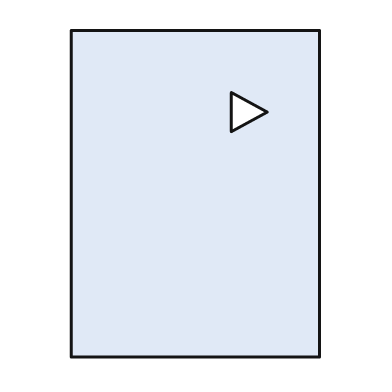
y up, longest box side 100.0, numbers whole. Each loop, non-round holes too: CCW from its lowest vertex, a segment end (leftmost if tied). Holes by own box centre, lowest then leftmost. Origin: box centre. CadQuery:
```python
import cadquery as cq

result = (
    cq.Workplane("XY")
    .moveTo(-38.0, -50.0)
    .lineTo(38.0, -50.0)
    .lineTo(38.0, 50.0)
    .lineTo(-38.0, 50.0)
    .close()
    .moveTo(11.0, 19.0)
    .lineTo(22.0, 25.0)
    .lineTo(11.0, 31.0)
    .close()
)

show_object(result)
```